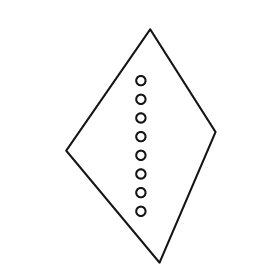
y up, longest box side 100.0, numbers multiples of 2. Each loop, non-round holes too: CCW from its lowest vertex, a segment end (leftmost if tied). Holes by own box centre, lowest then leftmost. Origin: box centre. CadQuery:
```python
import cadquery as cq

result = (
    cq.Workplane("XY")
    .moveTo(8.0, -50.0)
    .lineTo(32.0, 6.0)
    .lineTo(4.0, 50.0)
    .lineTo(-32.0, -2.0)
    .close()
    .moveTo(0.0, -28.0)
    .circle(2.0)
    .moveTo(0.0, -20.0)
    .circle(2.0)
    .moveTo(0.0, -12.0)
    .circle(2.0)
    .moveTo(0.0, -4.0)
    .circle(2.0)
    .moveTo(0.0, 4.0)
    .circle(2.0)
    .moveTo(0.0, 12.0)
    .circle(2.0)
    .moveTo(0.0, 20.0)
    .circle(2.0)
    .moveTo(0.0, 28.0)
    .circle(2.0)
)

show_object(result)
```